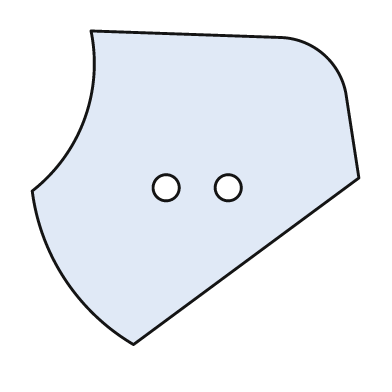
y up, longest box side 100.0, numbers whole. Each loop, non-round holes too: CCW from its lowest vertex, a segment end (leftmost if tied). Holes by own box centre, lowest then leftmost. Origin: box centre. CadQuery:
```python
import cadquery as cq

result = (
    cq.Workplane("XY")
    .moveTo(-19.0, -48.0)
    .lineTo(50.0, 3.0)
    .lineTo(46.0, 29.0)
    .threePointArc((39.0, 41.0), (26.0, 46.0))
    .lineTo(-32.0, 48.0)
    .threePointArc((-34.0, 21.0), (-50.0, -1.0))
    .threePointArc((-40.0, -28.0), (-19.0, -48.0))
    .close()
    .moveTo(-9.0, 0.0)
    .circle(4.0)
    .moveTo(10.0, 0.0)
    .circle(4.0)
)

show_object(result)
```